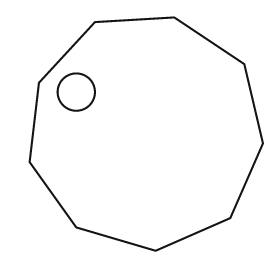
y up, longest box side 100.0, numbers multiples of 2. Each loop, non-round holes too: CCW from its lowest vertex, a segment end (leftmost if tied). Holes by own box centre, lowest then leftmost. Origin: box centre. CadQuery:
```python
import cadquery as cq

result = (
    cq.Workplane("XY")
    .moveTo(4.0, -50.0)
    .lineTo(36.0, -36.0)
    .lineTo(50.0, -4.0)
    .lineTo(42.0, 30.0)
    .lineTo(12.0, 50.0)
    .lineTo(-22.0, 48.0)
    .lineTo(-46.0, 22.0)
    .lineTo(-50.0, -12.0)
    .lineTo(-30.0, -40.0)
    .close()
    .moveTo(-30.0, 18.0)
    .circle(8.0)
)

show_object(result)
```